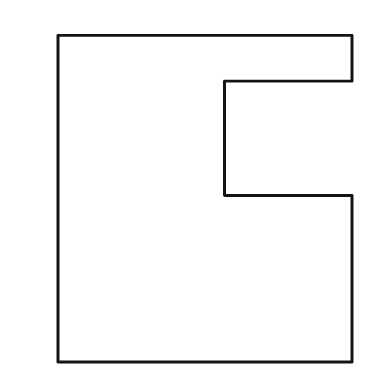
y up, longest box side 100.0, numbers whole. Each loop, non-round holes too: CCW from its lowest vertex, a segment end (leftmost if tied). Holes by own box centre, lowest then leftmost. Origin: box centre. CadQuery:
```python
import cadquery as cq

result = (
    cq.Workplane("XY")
    .moveTo(-45.0, -50.0)
    .lineTo(45.0, -50.0)
    .lineTo(45.0, 1.0)
    .lineTo(6.0, 1.0)
    .lineTo(6.0, 36.0)
    .lineTo(45.0, 36.0)
    .lineTo(45.0, 50.0)
    .lineTo(-45.0, 50.0)
    .close()
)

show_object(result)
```